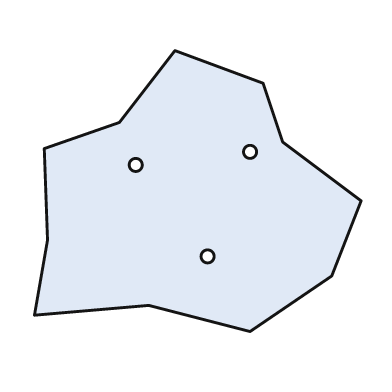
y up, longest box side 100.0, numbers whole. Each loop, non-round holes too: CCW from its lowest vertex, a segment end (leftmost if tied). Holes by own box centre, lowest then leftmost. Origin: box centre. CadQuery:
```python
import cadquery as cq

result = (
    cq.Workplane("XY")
    .moveTo(16.0, -43.0)
    .lineTo(41.0, -26.0)
    .lineTo(50.0, -3.0)
    .lineTo(26.0, 15.0)
    .lineTo(20.0, 33.0)
    .lineTo(-7.0, 43.0)
    .lineTo(-24.0, 21.0)
    .lineTo(-47.0, 13.0)
    .lineTo(-46.0, -15.0)
    .lineTo(-50.0, -38.0)
    .lineTo(-15.0, -35.0)
    .close()
    .moveTo(3.0, -20.0)
    .circle(2.0)
    .moveTo(-19.0, 8.0)
    .circle(2.0)
    .moveTo(16.0, 12.0)
    .circle(2.0)
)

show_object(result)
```